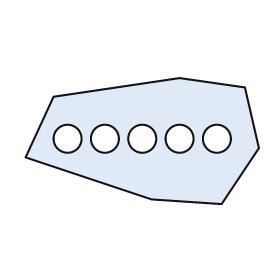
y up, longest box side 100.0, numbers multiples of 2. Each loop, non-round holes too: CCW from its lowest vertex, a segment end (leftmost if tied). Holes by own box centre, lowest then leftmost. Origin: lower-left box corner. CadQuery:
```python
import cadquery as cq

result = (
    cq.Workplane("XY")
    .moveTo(84.0, 0.0)
    .lineTo(100.0, 24.0)
    .lineTo(94.0, 50.0)
    .lineTo(66.0, 54.0)
    .lineTo(12.0, 46.0)
    .lineTo(0.0, 20.0)
    .lineTo(54.0, 2.0)
    .close()
    .moveTo(18.0, 28.0)
    .circle(6.0)
    .moveTo(34.0, 28.0)
    .circle(6.0)
    .moveTo(50.0, 28.0)
    .circle(6.0)
    .moveTo(66.0, 28.0)
    .circle(6.0)
    .moveTo(82.0, 28.0)
    .circle(6.0)
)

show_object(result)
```